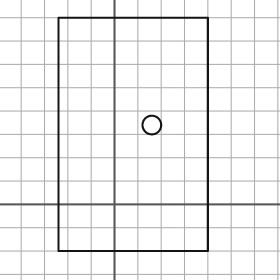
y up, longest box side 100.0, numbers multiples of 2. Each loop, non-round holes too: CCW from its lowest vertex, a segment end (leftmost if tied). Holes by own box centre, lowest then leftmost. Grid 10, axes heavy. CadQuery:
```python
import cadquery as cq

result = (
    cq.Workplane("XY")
    .moveTo(-24.0, -20.0)
    .lineTo(40.0, -20.0)
    .lineTo(40.0, 80.0)
    .lineTo(-24.0, 80.0)
    .close()
    .moveTo(16.0, 34.0)
    .circle(4.0)
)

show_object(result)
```